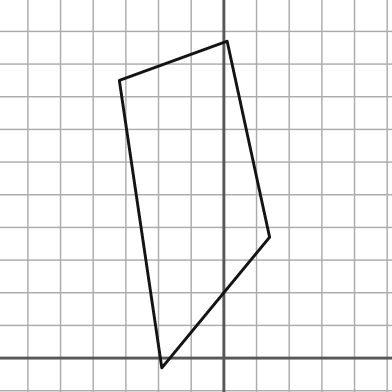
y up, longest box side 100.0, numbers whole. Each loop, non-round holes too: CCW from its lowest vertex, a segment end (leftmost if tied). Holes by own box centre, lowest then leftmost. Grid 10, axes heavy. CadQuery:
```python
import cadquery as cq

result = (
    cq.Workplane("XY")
    .moveTo(-19.0, -3.0)
    .lineTo(14.0, 37.0)
    .lineTo(1.0, 97.0)
    .lineTo(-32.0, 85.0)
    .close()
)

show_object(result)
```